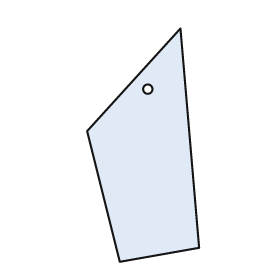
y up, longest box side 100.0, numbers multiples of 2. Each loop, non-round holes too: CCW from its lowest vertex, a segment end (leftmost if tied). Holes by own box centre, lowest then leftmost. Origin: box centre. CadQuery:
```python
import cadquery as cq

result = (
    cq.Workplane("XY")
    .moveTo(-10.0, -50.0)
    .lineTo(24.0, -44.0)
    .lineTo(16.0, 50.0)
    .lineTo(-24.0, 6.0)
    .close()
    .moveTo(2.0, 24.0)
    .circle(2.0)
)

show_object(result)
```